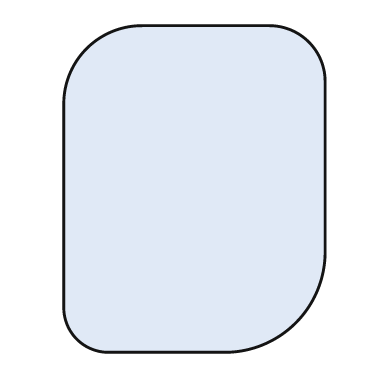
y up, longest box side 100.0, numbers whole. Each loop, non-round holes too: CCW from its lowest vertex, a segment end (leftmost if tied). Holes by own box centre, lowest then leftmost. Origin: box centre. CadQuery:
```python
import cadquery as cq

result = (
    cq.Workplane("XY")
    .moveTo(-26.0, -50.0)
    .lineTo(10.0, -50.0)
    .threePointArc((31.0, -41.0), (40.0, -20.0))
    .lineTo(40.0, 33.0)
    .threePointArc((35.0, 45.0), (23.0, 50.0))
    .lineTo(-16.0, 50.0)
    .threePointArc((-33.0, 43.0), (-40.0, 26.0))
    .lineTo(-40.0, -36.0)
    .threePointArc((-36.0, -46.0), (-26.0, -50.0))
    .close()
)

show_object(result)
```